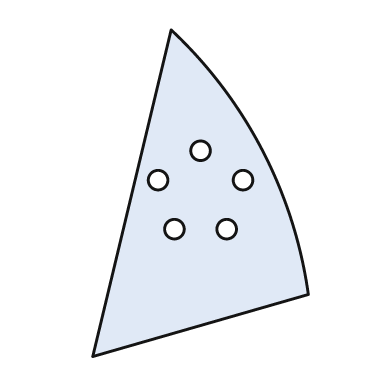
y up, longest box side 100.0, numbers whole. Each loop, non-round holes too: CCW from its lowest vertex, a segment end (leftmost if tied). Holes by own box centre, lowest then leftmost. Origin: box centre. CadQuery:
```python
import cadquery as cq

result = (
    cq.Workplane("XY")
    .moveTo(-33.0, -50.0)
    .lineTo(33.0, -31.0)
    .threePointArc((19.0, 13.0), (-9.0, 50.0))
    .close()
    .moveTo(-8.0, -11.0)
    .circle(3.0)
    .moveTo(8.0, -11.0)
    .circle(3.0)
    .moveTo(-13.0, 4.0)
    .circle(3.0)
    .moveTo(13.0, 4.0)
    .circle(3.0)
    .moveTo(0.0, 13.0)
    .circle(3.0)
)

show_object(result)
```